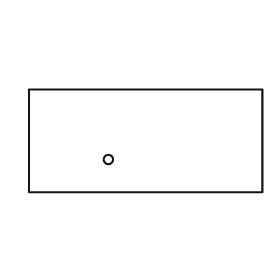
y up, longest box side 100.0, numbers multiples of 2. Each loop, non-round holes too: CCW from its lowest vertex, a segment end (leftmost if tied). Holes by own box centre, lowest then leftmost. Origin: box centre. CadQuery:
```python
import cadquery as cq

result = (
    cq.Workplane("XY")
    .moveTo(-50.0, -22.0)
    .lineTo(50.0, -22.0)
    .lineTo(50.0, 22.0)
    .lineTo(-50.0, 22.0)
    .close()
    .moveTo(-16.0, -8.0)
    .circle(2.0)
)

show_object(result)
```